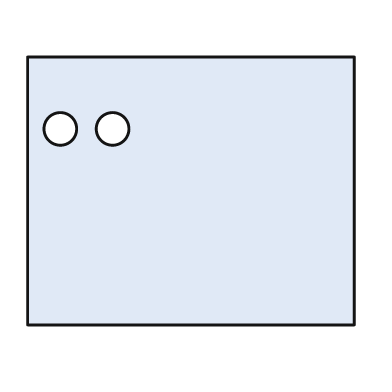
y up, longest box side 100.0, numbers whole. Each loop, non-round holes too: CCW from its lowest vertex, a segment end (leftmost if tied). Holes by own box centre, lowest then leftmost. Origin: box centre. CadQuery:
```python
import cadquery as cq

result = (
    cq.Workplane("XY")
    .moveTo(-50.0, -41.0)
    .lineTo(50.0, -41.0)
    .lineTo(50.0, 41.0)
    .lineTo(-50.0, 41.0)
    .close()
    .moveTo(-40.0, 19.0)
    .circle(5.0)
    .moveTo(-24.0, 19.0)
    .circle(5.0)
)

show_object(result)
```